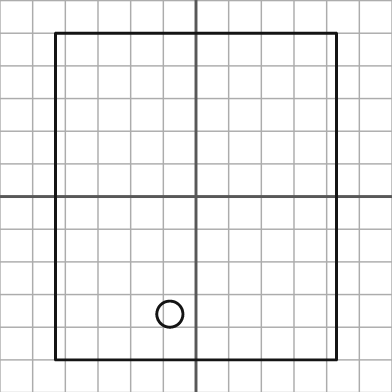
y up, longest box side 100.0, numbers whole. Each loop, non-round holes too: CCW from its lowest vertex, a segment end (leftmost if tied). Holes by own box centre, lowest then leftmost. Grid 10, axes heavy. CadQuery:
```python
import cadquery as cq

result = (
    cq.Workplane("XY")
    .moveTo(-43.0, -50.0)
    .lineTo(43.0, -50.0)
    .lineTo(43.0, 50.0)
    .lineTo(-43.0, 50.0)
    .close()
    .moveTo(-8.0, -36.0)
    .circle(4.0)
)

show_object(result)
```